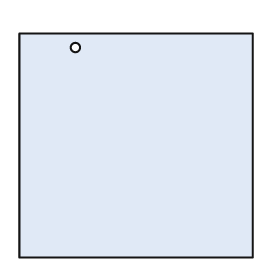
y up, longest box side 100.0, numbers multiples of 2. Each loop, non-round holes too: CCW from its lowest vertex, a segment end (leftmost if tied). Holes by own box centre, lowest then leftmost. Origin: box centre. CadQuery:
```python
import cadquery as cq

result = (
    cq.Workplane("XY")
    .moveTo(-50.0, -48.0)
    .lineTo(50.0, -48.0)
    .lineTo(50.0, 48.0)
    .lineTo(-50.0, 48.0)
    .close()
    .moveTo(-26.0, 42.0)
    .circle(2.0)
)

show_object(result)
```